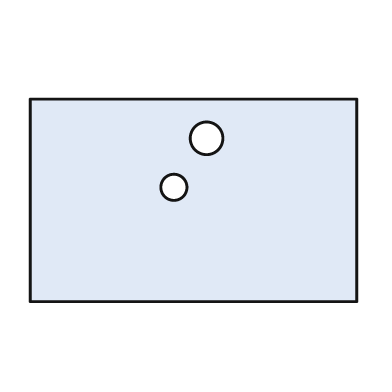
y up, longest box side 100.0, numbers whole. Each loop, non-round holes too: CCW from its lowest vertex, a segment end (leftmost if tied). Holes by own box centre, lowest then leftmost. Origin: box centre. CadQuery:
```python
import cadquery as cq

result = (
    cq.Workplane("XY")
    .moveTo(-50.0, -31.0)
    .lineTo(50.0, -31.0)
    .lineTo(50.0, 31.0)
    .lineTo(-50.0, 31.0)
    .close()
    .moveTo(-6.0, 4.0)
    .circle(4.0)
    .moveTo(4.0, 19.0)
    .circle(5.0)
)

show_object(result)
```